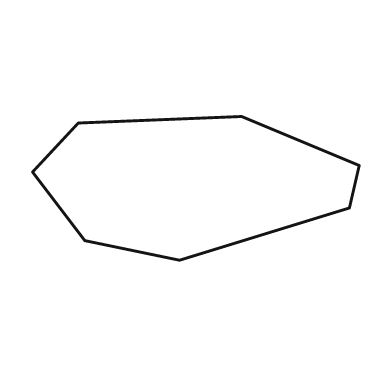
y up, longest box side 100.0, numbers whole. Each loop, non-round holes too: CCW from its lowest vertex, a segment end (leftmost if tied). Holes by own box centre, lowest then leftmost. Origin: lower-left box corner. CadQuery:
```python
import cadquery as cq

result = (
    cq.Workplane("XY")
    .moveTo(45.0, 0.0)
    .lineTo(97.0, 16.0)
    .lineTo(100.0, 29.0)
    .lineTo(64.0, 44.0)
    .lineTo(14.0, 42.0)
    .lineTo(0.0, 27.0)
    .lineTo(16.0, 6.0)
    .close()
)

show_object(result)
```